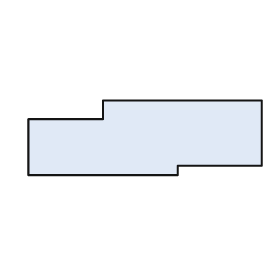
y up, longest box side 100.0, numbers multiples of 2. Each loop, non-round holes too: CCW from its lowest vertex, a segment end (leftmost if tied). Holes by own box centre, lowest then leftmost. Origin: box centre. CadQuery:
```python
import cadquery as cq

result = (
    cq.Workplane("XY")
    .moveTo(-50.0, -16.0)
    .lineTo(14.0, -16.0)
    .lineTo(14.0, -12.0)
    .lineTo(50.0, -12.0)
    .lineTo(50.0, 16.0)
    .lineTo(-18.0, 16.0)
    .lineTo(-18.0, 8.0)
    .lineTo(-50.0, 8.0)
    .close()
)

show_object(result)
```